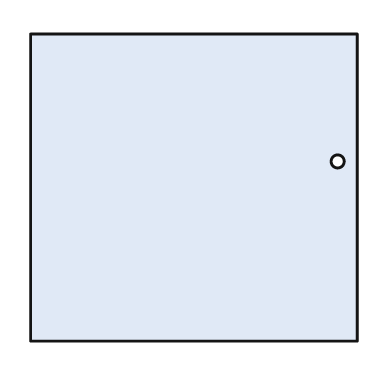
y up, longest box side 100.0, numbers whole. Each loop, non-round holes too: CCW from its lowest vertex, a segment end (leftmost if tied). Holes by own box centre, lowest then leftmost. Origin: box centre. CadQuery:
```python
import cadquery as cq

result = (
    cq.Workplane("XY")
    .moveTo(-50.0, -47.0)
    .lineTo(50.0, -47.0)
    .lineTo(50.0, 47.0)
    .lineTo(-50.0, 47.0)
    .close()
    .moveTo(44.0, 8.0)
    .circle(2.0)
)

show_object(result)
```